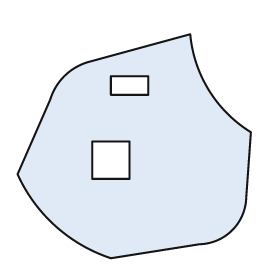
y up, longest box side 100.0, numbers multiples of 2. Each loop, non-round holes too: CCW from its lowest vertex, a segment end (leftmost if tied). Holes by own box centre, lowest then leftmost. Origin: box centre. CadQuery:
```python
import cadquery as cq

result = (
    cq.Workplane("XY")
    .moveTo(-10.0, -48.0)
    .lineTo(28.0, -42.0)
    .threePointArc((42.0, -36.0), (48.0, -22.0))
    .lineTo(50.0, 6.0)
    .threePointArc((32.0, 24.0), (24.0, 48.0))
    .lineTo(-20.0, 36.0)
    .threePointArc((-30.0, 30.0), (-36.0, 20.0))
    .lineTo(-50.0, -12.0)
    .threePointArc((-34.0, -34.0), (-10.0, -48.0))
    .close()
    .moveTo(-18.0, -14.0)
    .lineTo(-2.0, -14.0)
    .lineTo(-2.0, 2.0)
    .lineTo(-18.0, 2.0)
    .close()
    .moveTo(-10.0, 22.0)
    .lineTo(6.0, 22.0)
    .lineTo(6.0, 30.0)
    .lineTo(-10.0, 30.0)
    .close()
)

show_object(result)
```